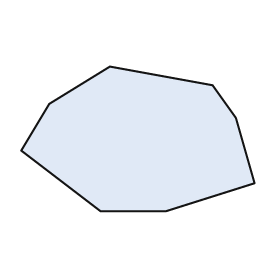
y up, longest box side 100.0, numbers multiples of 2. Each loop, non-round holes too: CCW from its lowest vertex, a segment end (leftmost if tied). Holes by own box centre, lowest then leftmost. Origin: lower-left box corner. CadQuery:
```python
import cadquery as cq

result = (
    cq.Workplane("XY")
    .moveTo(34.0, 0.0)
    .lineTo(62.0, 0.0)
    .lineTo(100.0, 12.0)
    .lineTo(92.0, 40.0)
    .lineTo(82.0, 54.0)
    .lineTo(38.0, 62.0)
    .lineTo(12.0, 46.0)
    .lineTo(0.0, 26.0)
    .close()
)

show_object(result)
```